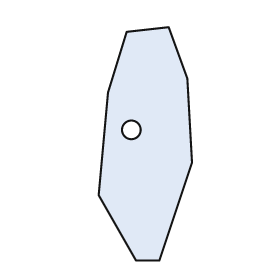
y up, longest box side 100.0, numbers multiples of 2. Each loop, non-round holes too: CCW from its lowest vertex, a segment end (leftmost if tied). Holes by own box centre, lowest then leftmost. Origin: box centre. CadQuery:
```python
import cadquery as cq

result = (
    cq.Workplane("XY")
    .moveTo(-4.0, -50.0)
    .lineTo(6.0, -50.0)
    .lineTo(20.0, -8.0)
    .lineTo(18.0, 28.0)
    .lineTo(10.0, 50.0)
    .lineTo(-8.0, 48.0)
    .lineTo(-16.0, 22.0)
    .lineTo(-20.0, -22.0)
    .close()
    .moveTo(-6.0, 6.0)
    .circle(4.0)
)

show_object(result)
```